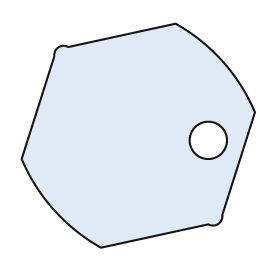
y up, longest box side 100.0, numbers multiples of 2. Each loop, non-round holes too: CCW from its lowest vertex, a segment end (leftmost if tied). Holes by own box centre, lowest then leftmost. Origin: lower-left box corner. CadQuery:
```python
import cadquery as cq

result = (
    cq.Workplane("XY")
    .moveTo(34.0, 0.0)
    .lineTo(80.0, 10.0)
    .threePointArc((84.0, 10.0), (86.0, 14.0))
    .lineTo(100.0, 58.0)
    .threePointArc((86.0, 80.0), (66.0, 96.0))
    .lineTo(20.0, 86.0)
    .threePointArc((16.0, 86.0), (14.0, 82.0))
    .lineTo(0.0, 38.0)
    .threePointArc((14.0, 16.0), (34.0, 0.0))
    .close()
    .moveTo(80.0, 46.0)
    .circle(8.0)
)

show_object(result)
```